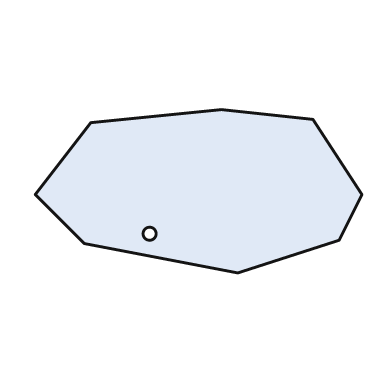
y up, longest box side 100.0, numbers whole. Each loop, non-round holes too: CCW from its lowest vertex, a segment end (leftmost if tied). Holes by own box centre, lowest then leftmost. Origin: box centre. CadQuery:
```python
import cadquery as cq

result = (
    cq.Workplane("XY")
    .moveTo(12.0, -25.0)
    .lineTo(43.0, -15.0)
    .lineTo(50.0, -1.0)
    .lineTo(35.0, 22.0)
    .lineTo(7.0, 25.0)
    .lineTo(-33.0, 21.0)
    .lineTo(-50.0, -1.0)
    .lineTo(-35.0, -16.0)
    .close()
    .moveTo(-15.0, -13.0)
    .circle(2.0)
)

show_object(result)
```